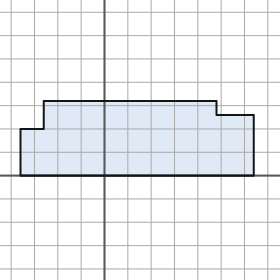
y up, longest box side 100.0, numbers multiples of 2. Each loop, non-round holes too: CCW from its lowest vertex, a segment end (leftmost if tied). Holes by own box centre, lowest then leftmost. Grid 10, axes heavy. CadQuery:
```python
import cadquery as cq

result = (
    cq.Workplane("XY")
    .moveTo(-36.0, 0.0)
    .lineTo(64.0, 0.0)
    .lineTo(64.0, 26.0)
    .lineTo(48.0, 26.0)
    .lineTo(48.0, 32.0)
    .lineTo(-26.0, 32.0)
    .lineTo(-26.0, 20.0)
    .lineTo(-36.0, 20.0)
    .close()
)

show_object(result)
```